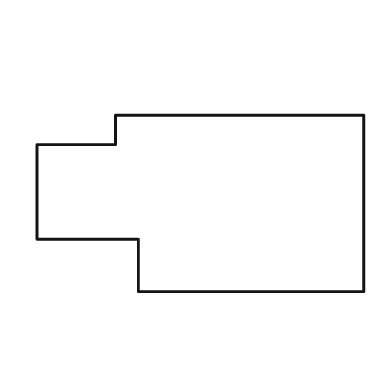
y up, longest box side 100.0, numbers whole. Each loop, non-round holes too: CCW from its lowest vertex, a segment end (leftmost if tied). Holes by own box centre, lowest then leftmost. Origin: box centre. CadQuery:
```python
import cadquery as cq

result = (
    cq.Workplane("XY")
    .moveTo(-19.0, -27.0)
    .lineTo(50.0, -27.0)
    .lineTo(50.0, 27.0)
    .lineTo(-26.0, 27.0)
    .lineTo(-26.0, 18.0)
    .lineTo(-50.0, 18.0)
    .lineTo(-50.0, -11.0)
    .lineTo(-19.0, -11.0)
    .close()
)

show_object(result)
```